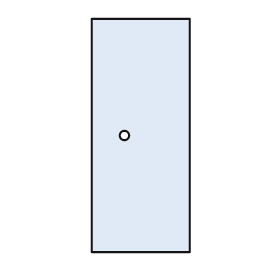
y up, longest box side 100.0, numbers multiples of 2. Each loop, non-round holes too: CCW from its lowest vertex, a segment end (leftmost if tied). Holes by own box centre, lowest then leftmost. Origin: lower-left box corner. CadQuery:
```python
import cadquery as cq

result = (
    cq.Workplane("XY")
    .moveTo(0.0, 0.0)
    .lineTo(42.0, 0.0)
    .lineTo(42.0, 100.0)
    .lineTo(0.0, 100.0)
    .close()
    .moveTo(14.0, 50.0)
    .circle(2.0)
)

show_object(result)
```